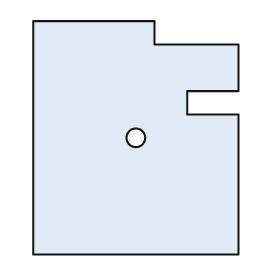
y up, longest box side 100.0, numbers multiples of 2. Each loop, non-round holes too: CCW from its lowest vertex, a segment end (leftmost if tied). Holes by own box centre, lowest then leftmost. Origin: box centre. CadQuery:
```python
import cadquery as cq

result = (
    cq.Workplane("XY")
    .moveTo(-44.0, -50.0)
    .lineTo(44.0, -50.0)
    .lineTo(44.0, 10.0)
    .lineTo(22.0, 10.0)
    .lineTo(22.0, 20.0)
    .lineTo(44.0, 20.0)
    .lineTo(44.0, 40.0)
    .lineTo(8.0, 40.0)
    .lineTo(8.0, 50.0)
    .lineTo(-44.0, 50.0)
    .close()
    .moveTo(0.0, 0.0)
    .circle(4.0)
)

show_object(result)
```